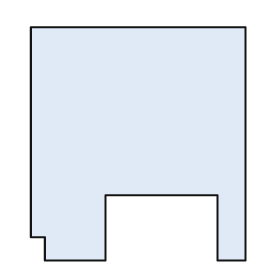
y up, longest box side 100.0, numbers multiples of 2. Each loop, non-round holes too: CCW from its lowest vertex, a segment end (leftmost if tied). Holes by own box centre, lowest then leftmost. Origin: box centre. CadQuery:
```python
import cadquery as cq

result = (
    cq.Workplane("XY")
    .moveTo(-40.0, -50.0)
    .lineTo(-14.0, -50.0)
    .lineTo(-14.0, -22.0)
    .lineTo(34.0, -22.0)
    .lineTo(34.0, -50.0)
    .lineTo(46.0, -50.0)
    .lineTo(46.0, 50.0)
    .lineTo(-46.0, 50.0)
    .lineTo(-46.0, -40.0)
    .lineTo(-40.0, -40.0)
    .close()
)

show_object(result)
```